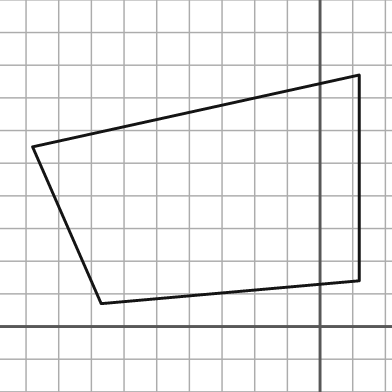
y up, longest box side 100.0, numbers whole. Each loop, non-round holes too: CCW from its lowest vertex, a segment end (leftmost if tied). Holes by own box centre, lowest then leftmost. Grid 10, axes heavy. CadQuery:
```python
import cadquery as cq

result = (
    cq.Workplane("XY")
    .moveTo(-67.0, 7.0)
    .lineTo(12.0, 14.0)
    .lineTo(12.0, 77.0)
    .lineTo(-88.0, 55.0)
    .close()
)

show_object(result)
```